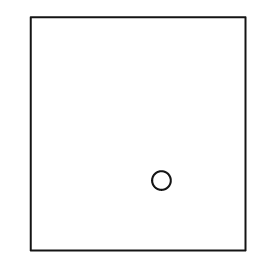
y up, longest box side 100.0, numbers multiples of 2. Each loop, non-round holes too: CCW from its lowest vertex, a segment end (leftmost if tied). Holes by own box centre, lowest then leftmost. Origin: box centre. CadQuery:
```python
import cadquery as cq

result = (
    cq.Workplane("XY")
    .moveTo(-46.0, -50.0)
    .lineTo(46.0, -50.0)
    .lineTo(46.0, 50.0)
    .lineTo(-46.0, 50.0)
    .close()
    .moveTo(10.0, -20.0)
    .circle(4.0)
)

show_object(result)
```